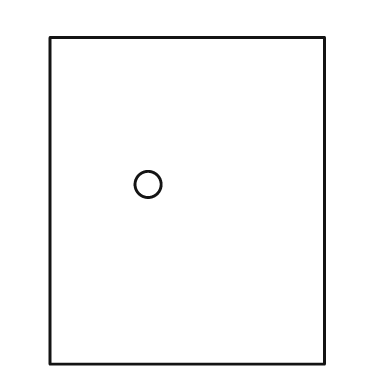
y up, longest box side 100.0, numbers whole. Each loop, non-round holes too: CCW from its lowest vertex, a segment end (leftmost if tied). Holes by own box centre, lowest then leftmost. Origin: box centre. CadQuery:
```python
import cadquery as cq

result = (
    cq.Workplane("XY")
    .moveTo(-42.0, -50.0)
    .lineTo(42.0, -50.0)
    .lineTo(42.0, 50.0)
    .lineTo(-42.0, 50.0)
    .close()
    .moveTo(-12.0, 5.0)
    .circle(4.0)
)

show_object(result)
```